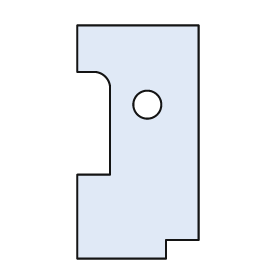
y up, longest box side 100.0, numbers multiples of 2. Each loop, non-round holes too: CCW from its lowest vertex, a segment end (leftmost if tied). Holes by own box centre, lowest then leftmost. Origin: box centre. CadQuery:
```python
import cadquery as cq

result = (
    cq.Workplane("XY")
    .moveTo(-26.0, -50.0)
    .lineTo(12.0, -50.0)
    .lineTo(12.0, -42.0)
    .lineTo(26.0, -42.0)
    .lineTo(26.0, 50.0)
    .lineTo(-26.0, 50.0)
    .lineTo(-26.0, 30.0)
    .lineTo(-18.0, 30.0)
    .threePointArc((-14.0, 28.0), (-12.0, 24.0))
    .lineTo(-12.0, -14.0)
    .lineTo(-26.0, -14.0)
    .close()
    .moveTo(4.0, 16.0)
    .circle(6.0)
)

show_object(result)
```